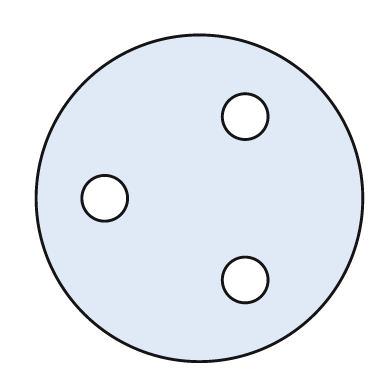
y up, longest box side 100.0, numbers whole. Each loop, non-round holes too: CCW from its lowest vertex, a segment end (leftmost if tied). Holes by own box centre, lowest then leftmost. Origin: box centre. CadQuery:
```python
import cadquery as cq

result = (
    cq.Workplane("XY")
    .moveTo(0.0, 0.0)
    .circle(50.0)
    .moveTo(14.0, -25.0)
    .circle(7.0)
    .moveTo(-29.0, 0.0)
    .circle(7.0)
    .moveTo(14.0, 25.0)
    .circle(7.0)
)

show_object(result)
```